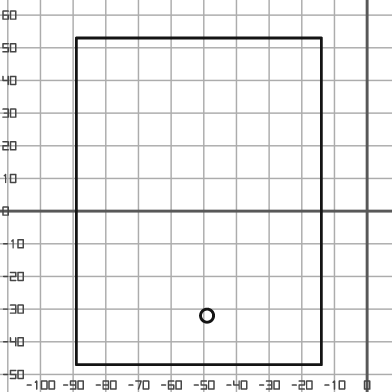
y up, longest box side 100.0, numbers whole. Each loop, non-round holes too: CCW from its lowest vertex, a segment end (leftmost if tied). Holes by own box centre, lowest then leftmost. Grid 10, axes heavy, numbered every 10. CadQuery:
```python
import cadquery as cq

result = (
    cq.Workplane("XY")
    .moveTo(-89.0, -47.0)
    .lineTo(-14.0, -47.0)
    .lineTo(-14.0, 53.0)
    .lineTo(-89.0, 53.0)
    .close()
    .moveTo(-49.0, -32.0)
    .circle(2.0)
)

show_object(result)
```